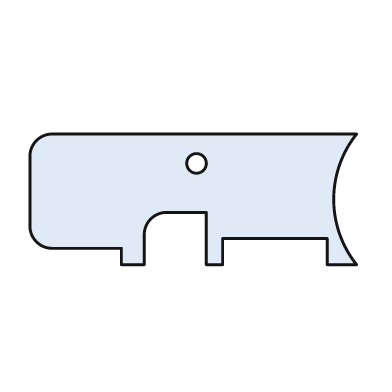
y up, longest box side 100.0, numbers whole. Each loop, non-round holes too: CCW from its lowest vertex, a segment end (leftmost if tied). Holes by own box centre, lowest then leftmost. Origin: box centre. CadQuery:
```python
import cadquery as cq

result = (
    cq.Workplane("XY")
    .moveTo(-22.0, -20.0)
    .lineTo(-15.0, -20.0)
    .lineTo(-15.0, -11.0)
    .threePointArc((-13.0, -6.0), (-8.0, -4.0))
    .lineTo(4.0, -4.0)
    .lineTo(4.0, -20.0)
    .lineTo(9.0, -20.0)
    .lineTo(9.0, -12.0)
    .lineTo(41.0, -12.0)
    .lineTo(41.0, -20.0)
    .lineTo(50.0, -20.0)
    .threePointArc((43.0, 0.0), (50.0, 20.0))
    .lineTo(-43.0, 20.0)
    .threePointArc((-48.0, 18.0), (-50.0, 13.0))
    .lineTo(-50.0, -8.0)
    .threePointArc((-48.0, -13.0), (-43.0, -15.0))
    .lineTo(-22.0, -15.0)
    .close()
    .moveTo(1.0, 11.0)
    .circle(3.0)
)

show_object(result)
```